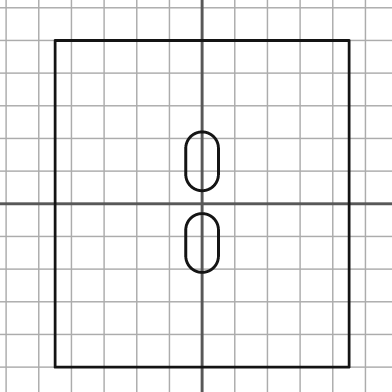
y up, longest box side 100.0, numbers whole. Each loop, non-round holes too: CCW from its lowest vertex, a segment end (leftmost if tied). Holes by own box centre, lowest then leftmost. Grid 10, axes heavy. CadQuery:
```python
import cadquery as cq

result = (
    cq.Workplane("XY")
    .moveTo(-45.0, -50.0)
    .lineTo(45.0, -50.0)
    .lineTo(45.0, 50.0)
    .lineTo(-45.0, 50.0)
    .close()
    .moveTo(-5.0, -16.0)
    .threePointArc((0.0, -21.0), (5.0, -16.0))
    .lineTo(5.0, -8.0)
    .threePointArc((0.0, -3.0), (-5.0, -8.0))
    .close()
    .moveTo(-5.0, 9.0)
    .threePointArc((0.0, 4.0), (5.0, 9.0))
    .lineTo(5.0, 17.0)
    .threePointArc((0.0, 22.0), (-5.0, 17.0))
    .close()
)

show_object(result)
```